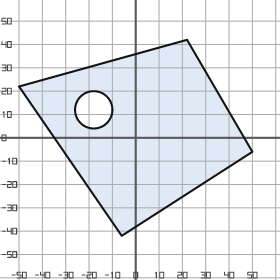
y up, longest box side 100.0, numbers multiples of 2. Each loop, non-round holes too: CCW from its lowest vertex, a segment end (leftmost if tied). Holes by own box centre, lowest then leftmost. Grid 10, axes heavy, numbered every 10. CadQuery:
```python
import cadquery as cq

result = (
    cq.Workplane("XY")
    .moveTo(-6.0, -42.0)
    .lineTo(50.0, -6.0)
    .lineTo(22.0, 42.0)
    .lineTo(-50.0, 22.0)
    .close()
    .moveTo(-18.0, 12.0)
    .circle(8.0)
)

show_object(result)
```